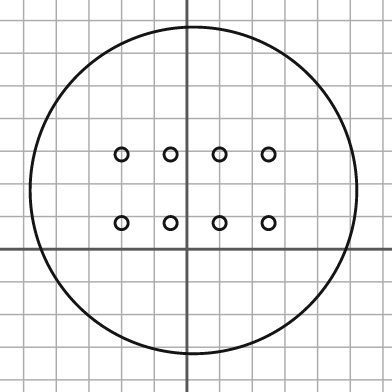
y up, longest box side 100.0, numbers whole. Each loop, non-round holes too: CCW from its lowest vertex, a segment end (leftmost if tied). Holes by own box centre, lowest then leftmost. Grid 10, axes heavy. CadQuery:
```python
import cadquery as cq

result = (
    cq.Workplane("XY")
    .moveTo(2.0, 18.0)
    .circle(50.0)
    .moveTo(-20.0, 8.0)
    .circle(2.0)
    .moveTo(-5.0, 8.0)
    .circle(2.0)
    .moveTo(10.0, 8.0)
    .circle(2.0)
    .moveTo(25.0, 8.0)
    .circle(2.0)
    .moveTo(-20.0, 29.0)
    .circle(2.0)
    .moveTo(-5.0, 29.0)
    .circle(2.0)
    .moveTo(10.0, 29.0)
    .circle(2.0)
    .moveTo(25.0, 29.0)
    .circle(2.0)
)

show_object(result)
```